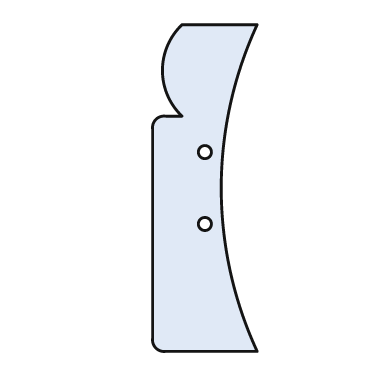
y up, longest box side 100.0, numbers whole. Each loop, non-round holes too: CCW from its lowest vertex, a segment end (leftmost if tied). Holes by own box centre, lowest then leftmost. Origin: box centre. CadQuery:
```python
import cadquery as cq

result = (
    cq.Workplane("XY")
    .moveTo(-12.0, -50.0)
    .lineTo(16.0, -50.0)
    .threePointArc((5.0, 0.0), (16.0, 50.0))
    .lineTo(-7.0, 50.0)
    .threePointArc((-13.0, 36.0), (-7.0, 22.0))
    .lineTo(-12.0, 22.0)
    .threePointArc((-15.0, 21.0), (-16.0, 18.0))
    .lineTo(-16.0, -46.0)
    .threePointArc((-15.0, -49.0), (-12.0, -50.0))
    .close()
    .moveTo(0.0, -11.0)
    .circle(2.0)
    .moveTo(0.0, 11.0)
    .circle(2.0)
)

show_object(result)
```